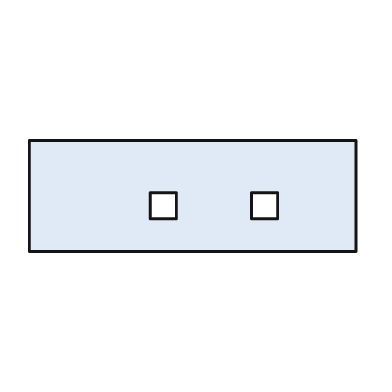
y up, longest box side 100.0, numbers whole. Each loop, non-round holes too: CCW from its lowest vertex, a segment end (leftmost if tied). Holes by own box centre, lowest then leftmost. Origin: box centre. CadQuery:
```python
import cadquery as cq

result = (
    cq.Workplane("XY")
    .moveTo(-50.0, -17.0)
    .lineTo(50.0, -17.0)
    .lineTo(50.0, 17.0)
    .lineTo(-50.0, 17.0)
    .close()
    .moveTo(-13.0, -7.0)
    .lineTo(-5.0, -7.0)
    .lineTo(-5.0, 1.0)
    .lineTo(-13.0, 1.0)
    .close()
    .moveTo(18.0, -7.0)
    .lineTo(26.0, -7.0)
    .lineTo(26.0, 1.0)
    .lineTo(18.0, 1.0)
    .close()
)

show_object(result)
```